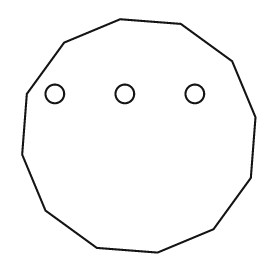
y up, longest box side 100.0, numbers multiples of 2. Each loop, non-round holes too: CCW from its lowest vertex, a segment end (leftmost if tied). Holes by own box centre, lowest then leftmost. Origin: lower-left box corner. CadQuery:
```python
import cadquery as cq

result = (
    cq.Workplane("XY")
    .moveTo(58.0, 0.0)
    .lineTo(82.0, 10.0)
    .lineTo(98.0, 32.0)
    .lineTo(100.0, 58.0)
    .lineTo(90.0, 82.0)
    .lineTo(68.0, 98.0)
    .lineTo(42.0, 100.0)
    .lineTo(18.0, 90.0)
    .lineTo(2.0, 68.0)
    .lineTo(0.0, 42.0)
    .lineTo(10.0, 18.0)
    .lineTo(32.0, 2.0)
    .close()
    .moveTo(14.0, 68.0)
    .circle(4.0)
    .moveTo(44.0, 68.0)
    .circle(4.0)
    .moveTo(74.0, 68.0)
    .circle(4.0)
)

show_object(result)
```